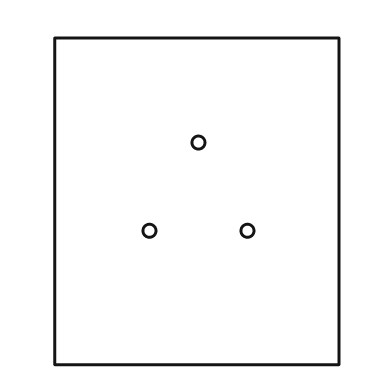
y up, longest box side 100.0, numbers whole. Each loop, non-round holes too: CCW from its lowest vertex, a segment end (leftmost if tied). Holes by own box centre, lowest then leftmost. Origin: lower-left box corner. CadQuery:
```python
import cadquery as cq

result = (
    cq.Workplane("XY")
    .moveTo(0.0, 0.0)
    .lineTo(87.0, 0.0)
    .lineTo(87.0, 100.0)
    .lineTo(0.0, 100.0)
    .close()
    .moveTo(29.0, 41.0)
    .circle(2.0)
    .moveTo(59.0, 41.0)
    .circle(2.0)
    .moveTo(44.0, 68.0)
    .circle(2.0)
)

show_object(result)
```